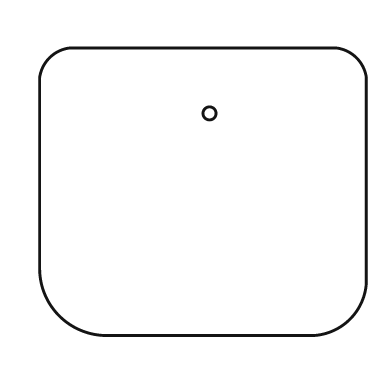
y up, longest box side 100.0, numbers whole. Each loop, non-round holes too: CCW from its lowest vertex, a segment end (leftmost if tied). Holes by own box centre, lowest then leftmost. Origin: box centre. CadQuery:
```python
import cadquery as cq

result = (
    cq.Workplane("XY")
    .moveTo(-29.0, -44.0)
    .lineTo(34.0, -44.0)
    .threePointArc((45.0, -39.0), (50.0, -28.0))
    .lineTo(50.0, 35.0)
    .threePointArc((47.0, 41.0), (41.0, 44.0))
    .lineTo(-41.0, 44.0)
    .threePointArc((-47.0, 41.0), (-50.0, 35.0))
    .lineTo(-50.0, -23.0)
    .threePointArc((-44.0, -38.0), (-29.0, -44.0))
    .close()
    .moveTo(2.0, 24.0)
    .circle(2.0)
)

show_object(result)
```